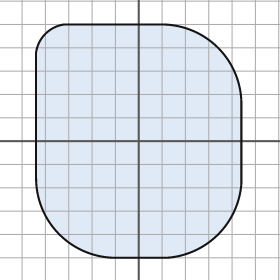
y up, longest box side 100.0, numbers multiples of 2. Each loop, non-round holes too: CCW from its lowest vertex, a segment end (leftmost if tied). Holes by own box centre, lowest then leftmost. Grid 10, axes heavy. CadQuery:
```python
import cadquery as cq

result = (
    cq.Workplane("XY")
    .moveTo(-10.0, -50.0)
    .lineTo(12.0, -50.0)
    .threePointArc((34.0, -40.0), (44.0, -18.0))
    .lineTo(44.0, 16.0)
    .threePointArc((34.0, 40.0), (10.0, 50.0))
    .lineTo(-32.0, 50.0)
    .threePointArc((-40.0, 46.0), (-44.0, 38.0))
    .lineTo(-44.0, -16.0)
    .threePointArc((-34.0, -40.0), (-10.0, -50.0))
    .close()
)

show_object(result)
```